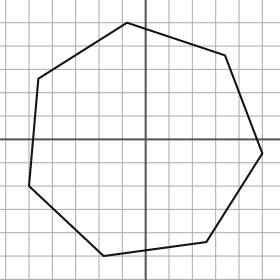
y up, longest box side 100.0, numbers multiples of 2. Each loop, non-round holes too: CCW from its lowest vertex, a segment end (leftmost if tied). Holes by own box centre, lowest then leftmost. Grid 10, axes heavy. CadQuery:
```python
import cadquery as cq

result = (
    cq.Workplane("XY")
    .moveTo(-18.0, -50.0)
    .lineTo(26.0, -44.0)
    .lineTo(50.0, -6.0)
    .lineTo(34.0, 36.0)
    .lineTo(-8.0, 50.0)
    .lineTo(-46.0, 26.0)
    .lineTo(-50.0, -20.0)
    .close()
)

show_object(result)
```